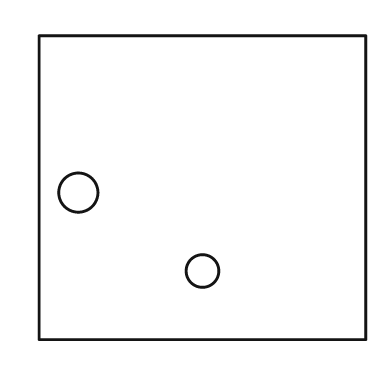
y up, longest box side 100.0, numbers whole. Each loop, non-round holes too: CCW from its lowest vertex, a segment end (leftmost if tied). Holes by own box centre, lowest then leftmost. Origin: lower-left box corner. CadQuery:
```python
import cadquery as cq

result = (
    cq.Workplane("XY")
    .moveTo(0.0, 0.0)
    .lineTo(100.0, 0.0)
    .lineTo(100.0, 93.0)
    .lineTo(0.0, 93.0)
    .close()
    .moveTo(50.0, 21.0)
    .circle(5.0)
    .moveTo(12.0, 45.0)
    .circle(6.0)
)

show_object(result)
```